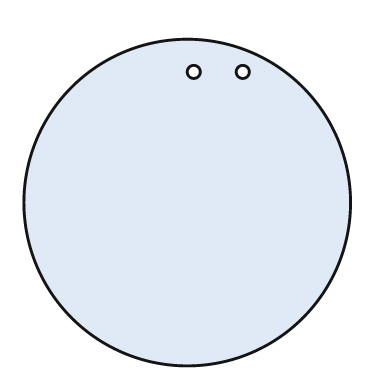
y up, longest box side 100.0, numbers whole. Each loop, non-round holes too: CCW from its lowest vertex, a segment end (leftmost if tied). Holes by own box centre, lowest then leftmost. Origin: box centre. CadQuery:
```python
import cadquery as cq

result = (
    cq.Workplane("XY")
    .moveTo(0.0, 0.0)
    .circle(50.0)
    .moveTo(2.0, 40.0)
    .circle(2.0)
    .moveTo(17.0, 40.0)
    .circle(2.0)
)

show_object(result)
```